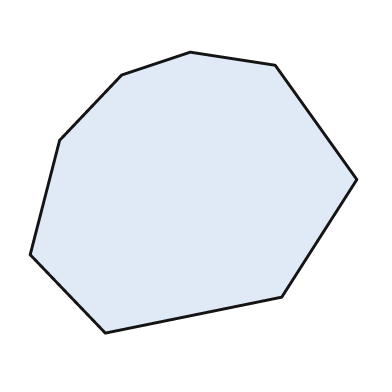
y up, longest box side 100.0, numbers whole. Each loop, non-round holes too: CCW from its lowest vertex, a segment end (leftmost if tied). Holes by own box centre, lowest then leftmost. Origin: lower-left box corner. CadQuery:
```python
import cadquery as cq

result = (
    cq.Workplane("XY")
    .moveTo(23.0, 0.0)
    .lineTo(77.0, 11.0)
    .lineTo(100.0, 47.0)
    .lineTo(75.0, 82.0)
    .lineTo(49.0, 86.0)
    .lineTo(28.0, 79.0)
    .lineTo(9.0, 59.0)
    .lineTo(0.0, 24.0)
    .close()
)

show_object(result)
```